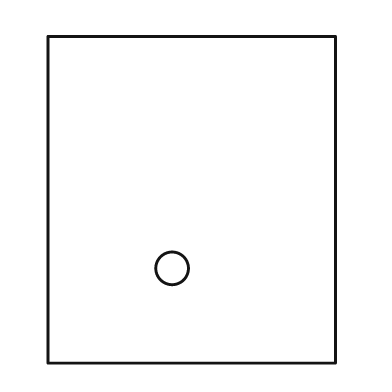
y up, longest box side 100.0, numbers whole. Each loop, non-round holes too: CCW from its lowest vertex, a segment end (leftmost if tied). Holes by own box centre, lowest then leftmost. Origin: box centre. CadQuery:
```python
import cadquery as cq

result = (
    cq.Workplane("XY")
    .moveTo(-44.0, -50.0)
    .lineTo(44.0, -50.0)
    .lineTo(44.0, 50.0)
    .lineTo(-44.0, 50.0)
    .close()
    .moveTo(-6.0, -21.0)
    .circle(5.0)
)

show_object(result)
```